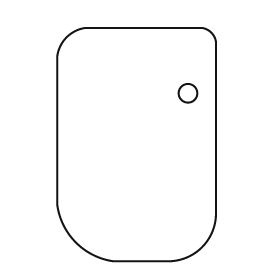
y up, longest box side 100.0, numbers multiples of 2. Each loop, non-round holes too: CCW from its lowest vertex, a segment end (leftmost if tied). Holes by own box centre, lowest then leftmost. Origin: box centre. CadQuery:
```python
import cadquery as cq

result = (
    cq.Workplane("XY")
    .moveTo(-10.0, -50.0)
    .lineTo(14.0, -50.0)
    .threePointArc((28.0, -44.0), (34.0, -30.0))
    .lineTo(34.0, 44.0)
    .threePointArc((32.0, 48.0), (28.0, 50.0))
    .lineTo(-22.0, 50.0)
    .threePointArc((-30.0, 46.0), (-34.0, 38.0))
    .lineTo(-34.0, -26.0)
    .threePointArc((-26.0, -42.0), (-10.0, -50.0))
    .close()
    .moveTo(22.0, 22.0)
    .circle(4.0)
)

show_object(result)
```